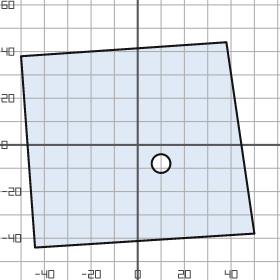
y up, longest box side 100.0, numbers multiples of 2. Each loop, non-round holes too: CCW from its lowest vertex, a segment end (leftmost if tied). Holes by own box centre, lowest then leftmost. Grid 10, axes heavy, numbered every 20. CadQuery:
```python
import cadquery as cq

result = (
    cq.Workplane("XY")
    .moveTo(-44.0, -44.0)
    .lineTo(50.0, -38.0)
    .lineTo(38.0, 44.0)
    .lineTo(-50.0, 38.0)
    .close()
    .moveTo(10.0, -8.0)
    .circle(4.0)
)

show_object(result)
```